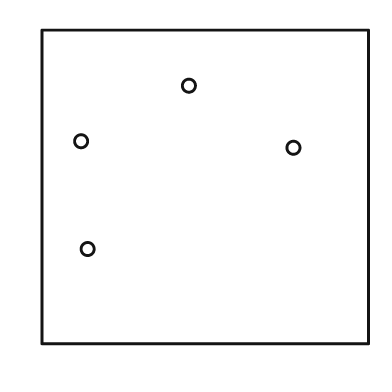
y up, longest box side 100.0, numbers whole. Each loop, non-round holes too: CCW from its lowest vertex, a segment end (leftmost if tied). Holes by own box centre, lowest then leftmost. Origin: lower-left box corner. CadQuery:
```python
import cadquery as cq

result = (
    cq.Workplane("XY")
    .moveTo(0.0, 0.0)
    .lineTo(100.0, 0.0)
    .lineTo(100.0, 96.0)
    .lineTo(0.0, 96.0)
    .close()
    .moveTo(14.0, 29.0)
    .circle(2.0)
    .moveTo(77.0, 60.0)
    .circle(2.0)
    .moveTo(12.0, 62.0)
    .circle(2.0)
    .moveTo(45.0, 79.0)
    .circle(2.0)
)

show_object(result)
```